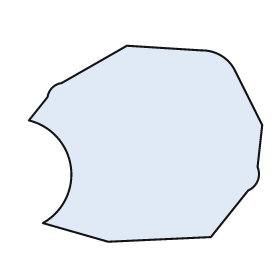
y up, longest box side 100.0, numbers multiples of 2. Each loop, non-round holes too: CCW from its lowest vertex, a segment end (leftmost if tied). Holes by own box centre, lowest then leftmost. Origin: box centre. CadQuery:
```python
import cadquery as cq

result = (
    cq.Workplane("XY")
    .moveTo(-16.0, -42.0)
    .lineTo(28.0, -40.0)
    .lineTo(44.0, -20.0)
    .threePointArc((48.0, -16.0), (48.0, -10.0))
    .lineTo(50.0, 8.0)
    .lineTo(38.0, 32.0)
    .threePointArc((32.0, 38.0), (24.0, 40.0))
    .lineTo(-8.0, 42.0)
    .lineTo(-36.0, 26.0)
    .threePointArc((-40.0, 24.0), (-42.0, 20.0))
    .lineTo(-50.0, 10.0)
    .threePointArc((-32.0, -10.0), (-44.0, -34.0))
    .close()
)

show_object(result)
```